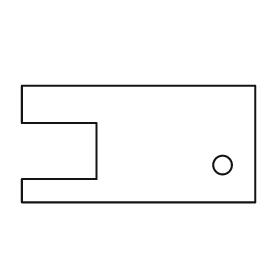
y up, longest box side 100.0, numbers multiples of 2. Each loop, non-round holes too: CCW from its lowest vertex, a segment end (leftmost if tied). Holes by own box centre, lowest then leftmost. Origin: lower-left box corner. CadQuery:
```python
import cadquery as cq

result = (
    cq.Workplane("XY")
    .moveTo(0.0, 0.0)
    .lineTo(100.0, 0.0)
    .lineTo(100.0, 50.0)
    .lineTo(0.0, 50.0)
    .lineTo(0.0, 34.0)
    .lineTo(32.0, 34.0)
    .lineTo(32.0, 10.0)
    .lineTo(0.0, 10.0)
    .close()
    .moveTo(86.0, 16.0)
    .circle(4.0)
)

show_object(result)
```